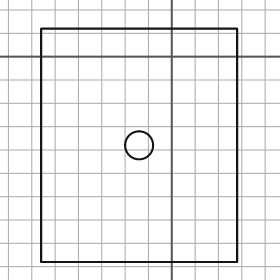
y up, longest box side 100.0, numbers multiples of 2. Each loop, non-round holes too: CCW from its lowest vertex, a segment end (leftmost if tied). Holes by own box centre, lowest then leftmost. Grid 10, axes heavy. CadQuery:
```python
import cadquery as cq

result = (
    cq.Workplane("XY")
    .moveTo(-56.0, -88.0)
    .lineTo(28.0, -88.0)
    .lineTo(28.0, 12.0)
    .lineTo(-56.0, 12.0)
    .close()
    .moveTo(-14.0, -38.0)
    .circle(6.0)
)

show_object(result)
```